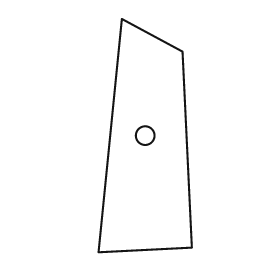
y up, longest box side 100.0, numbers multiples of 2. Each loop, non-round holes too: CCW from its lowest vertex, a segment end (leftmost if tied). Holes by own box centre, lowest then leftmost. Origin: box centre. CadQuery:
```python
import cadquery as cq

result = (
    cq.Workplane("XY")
    .moveTo(-20.0, -50.0)
    .lineTo(20.0, -48.0)
    .lineTo(16.0, 36.0)
    .lineTo(-10.0, 50.0)
    .close()
    .moveTo(0.0, 0.0)
    .circle(4.0)
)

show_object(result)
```